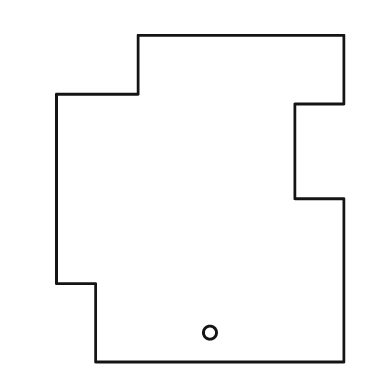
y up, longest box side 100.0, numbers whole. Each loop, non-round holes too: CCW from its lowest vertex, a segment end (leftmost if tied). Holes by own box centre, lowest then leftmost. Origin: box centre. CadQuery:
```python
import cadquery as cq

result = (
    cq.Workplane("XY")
    .moveTo(-32.0, -50.0)
    .lineTo(44.0, -50.0)
    .lineTo(44.0, 0.0)
    .lineTo(29.0, 0.0)
    .lineTo(29.0, 29.0)
    .lineTo(44.0, 29.0)
    .lineTo(44.0, 50.0)
    .lineTo(-19.0, 50.0)
    .lineTo(-19.0, 32.0)
    .lineTo(-44.0, 32.0)
    .lineTo(-44.0, -26.0)
    .lineTo(-32.0, -26.0)
    .close()
    .moveTo(3.0, -41.0)
    .circle(2.0)
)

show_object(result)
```